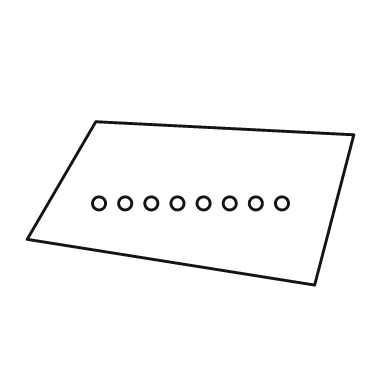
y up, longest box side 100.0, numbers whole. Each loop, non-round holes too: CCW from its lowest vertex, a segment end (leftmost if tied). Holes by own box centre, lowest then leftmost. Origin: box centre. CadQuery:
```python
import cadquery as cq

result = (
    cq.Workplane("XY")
    .moveTo(38.0, -25.0)
    .lineTo(50.0, 21.0)
    .lineTo(-29.0, 25.0)
    .lineTo(-50.0, -11.0)
    .close()
    .moveTo(-28.0, 0.0)
    .circle(2.0)
    .moveTo(-20.0, 0.0)
    .circle(2.0)
    .moveTo(-12.0, 0.0)
    .circle(2.0)
    .moveTo(-4.0, 0.0)
    .circle(2.0)
    .moveTo(4.0, 0.0)
    .circle(2.0)
    .moveTo(12.0, 0.0)
    .circle(2.0)
    .moveTo(20.0, 0.0)
    .circle(2.0)
    .moveTo(28.0, 0.0)
    .circle(2.0)
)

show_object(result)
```